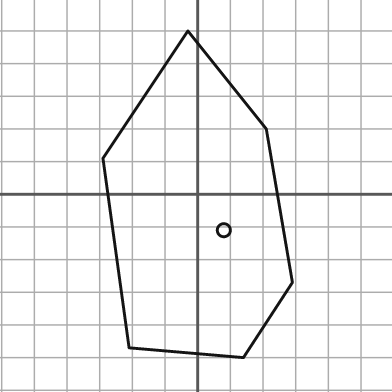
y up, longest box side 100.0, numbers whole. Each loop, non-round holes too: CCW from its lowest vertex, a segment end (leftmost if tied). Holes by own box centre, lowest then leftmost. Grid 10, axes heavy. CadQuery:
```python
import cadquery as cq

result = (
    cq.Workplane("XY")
    .moveTo(14.0, -50.0)
    .lineTo(29.0, -27.0)
    .lineTo(21.0, 20.0)
    .lineTo(-3.0, 50.0)
    .lineTo(-29.0, 11.0)
    .lineTo(-21.0, -47.0)
    .close()
    .moveTo(8.0, -11.0)
    .circle(2.0)
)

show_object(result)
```